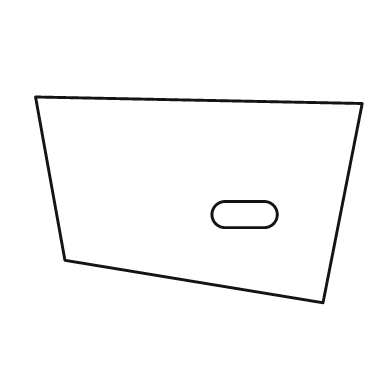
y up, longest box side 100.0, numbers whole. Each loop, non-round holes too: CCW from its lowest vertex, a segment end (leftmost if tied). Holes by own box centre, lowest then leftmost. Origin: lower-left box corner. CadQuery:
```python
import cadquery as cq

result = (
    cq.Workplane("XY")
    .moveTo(88.0, 0.0)
    .lineTo(100.0, 61.0)
    .lineTo(0.0, 63.0)
    .lineTo(9.0, 13.0)
    .close()
    .moveTo(58.0, 23.0)
    .lineTo(70.0, 23.0)
    .threePointArc((74.0, 27.0), (70.0, 31.0))
    .lineTo(58.0, 31.0)
    .threePointArc((54.0, 27.0), (58.0, 23.0))
    .close()
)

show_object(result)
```